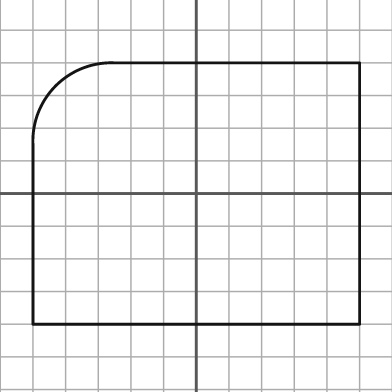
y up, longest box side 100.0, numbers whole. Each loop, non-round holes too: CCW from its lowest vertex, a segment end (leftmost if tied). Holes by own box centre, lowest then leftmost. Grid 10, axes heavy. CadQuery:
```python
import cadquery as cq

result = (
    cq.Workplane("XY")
    .moveTo(-50.0, -40.0)
    .lineTo(50.0, -40.0)
    .lineTo(50.0, 40.0)
    .lineTo(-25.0, 40.0)
    .threePointArc((-43.0, 33.0), (-50.0, 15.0))
    .close()
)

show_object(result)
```